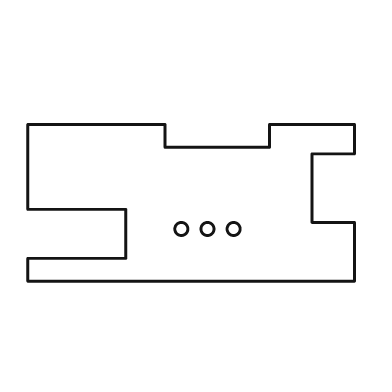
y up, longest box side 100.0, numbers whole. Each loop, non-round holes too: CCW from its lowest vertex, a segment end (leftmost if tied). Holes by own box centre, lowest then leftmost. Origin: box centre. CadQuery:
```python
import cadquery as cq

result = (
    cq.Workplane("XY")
    .moveTo(-50.0, -24.0)
    .lineTo(50.0, -24.0)
    .lineTo(50.0, -6.0)
    .lineTo(37.0, -6.0)
    .lineTo(37.0, 15.0)
    .lineTo(50.0, 15.0)
    .lineTo(50.0, 24.0)
    .lineTo(24.0, 24.0)
    .lineTo(24.0, 17.0)
    .lineTo(-8.0, 17.0)
    .lineTo(-8.0, 24.0)
    .lineTo(-50.0, 24.0)
    .lineTo(-50.0, -2.0)
    .lineTo(-20.0, -2.0)
    .lineTo(-20.0, -17.0)
    .lineTo(-50.0, -17.0)
    .close()
    .moveTo(-3.0, -8.0)
    .circle(2.0)
    .moveTo(5.0, -8.0)
    .circle(2.0)
    .moveTo(13.0, -8.0)
    .circle(2.0)
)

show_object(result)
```